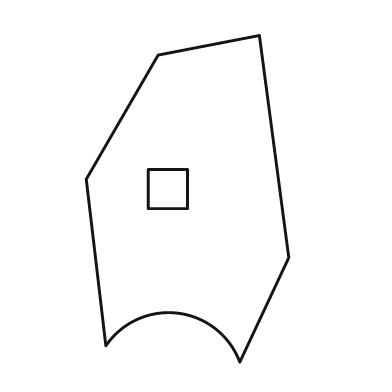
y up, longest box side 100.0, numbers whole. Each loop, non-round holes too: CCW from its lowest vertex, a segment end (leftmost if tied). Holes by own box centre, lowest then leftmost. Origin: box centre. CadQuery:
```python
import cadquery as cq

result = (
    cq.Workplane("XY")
    .moveTo(16.0, -50.0)
    .lineTo(31.0, -18.0)
    .lineTo(22.0, 50.0)
    .lineTo(-9.0, 44.0)
    .lineTo(-31.0, 6.0)
    .lineTo(-25.0, -45.0)
    .threePointArc((-3.0, -35.0), (16.0, -50.0))
    .close()
    .moveTo(-12.0, -3.0)
    .lineTo(0.0, -3.0)
    .lineTo(0.0, 9.0)
    .lineTo(-12.0, 9.0)
    .close()
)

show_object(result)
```